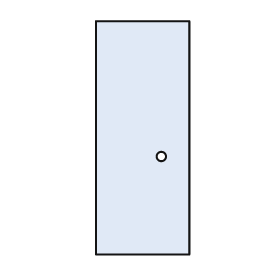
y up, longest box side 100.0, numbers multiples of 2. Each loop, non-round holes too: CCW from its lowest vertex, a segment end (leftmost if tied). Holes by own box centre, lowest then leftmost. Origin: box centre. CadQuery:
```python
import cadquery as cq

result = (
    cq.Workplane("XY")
    .moveTo(-20.0, -50.0)
    .lineTo(20.0, -50.0)
    .lineTo(20.0, 50.0)
    .lineTo(-20.0, 50.0)
    .close()
    .moveTo(8.0, -8.0)
    .circle(2.0)
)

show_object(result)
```